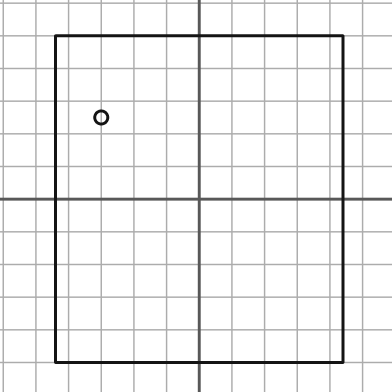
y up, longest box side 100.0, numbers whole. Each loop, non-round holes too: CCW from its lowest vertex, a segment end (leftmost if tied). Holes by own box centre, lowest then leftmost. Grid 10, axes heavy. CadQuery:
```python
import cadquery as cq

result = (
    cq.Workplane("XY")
    .moveTo(-44.0, -50.0)
    .lineTo(44.0, -50.0)
    .lineTo(44.0, 50.0)
    .lineTo(-44.0, 50.0)
    .close()
    .moveTo(-30.0, 25.0)
    .circle(2.0)
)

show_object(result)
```